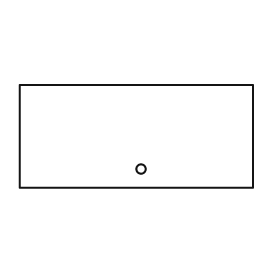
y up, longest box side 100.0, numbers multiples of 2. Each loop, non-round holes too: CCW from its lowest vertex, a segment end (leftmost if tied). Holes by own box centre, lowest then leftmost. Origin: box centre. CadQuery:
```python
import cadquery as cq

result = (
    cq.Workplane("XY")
    .moveTo(-50.0, -22.0)
    .lineTo(50.0, -22.0)
    .lineTo(50.0, 22.0)
    .lineTo(-50.0, 22.0)
    .close()
    .moveTo(2.0, -14.0)
    .circle(2.0)
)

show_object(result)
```